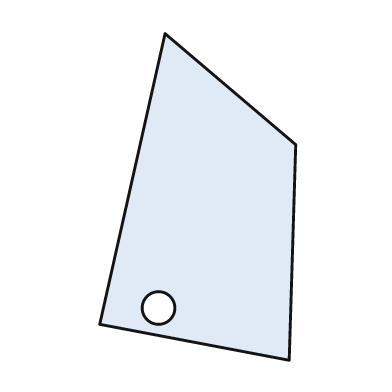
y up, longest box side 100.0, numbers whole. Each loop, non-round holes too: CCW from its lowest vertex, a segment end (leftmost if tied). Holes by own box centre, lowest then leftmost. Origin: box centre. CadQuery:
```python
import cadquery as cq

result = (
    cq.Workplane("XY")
    .moveTo(28.0, -50.0)
    .lineTo(30.0, 16.0)
    .lineTo(-10.0, 50.0)
    .lineTo(-30.0, -39.0)
    .close()
    .moveTo(-12.0, -34.0)
    .circle(5.0)
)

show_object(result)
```